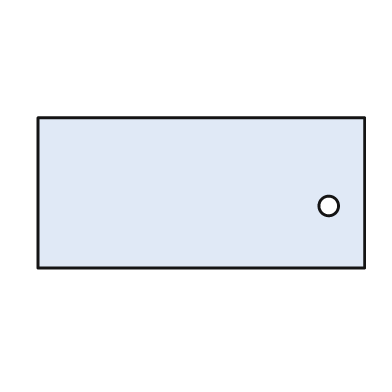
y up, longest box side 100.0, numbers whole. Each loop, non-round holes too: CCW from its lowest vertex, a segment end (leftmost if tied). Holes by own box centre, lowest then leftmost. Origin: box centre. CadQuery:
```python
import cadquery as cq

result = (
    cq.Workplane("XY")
    .moveTo(-50.0, -23.0)
    .lineTo(50.0, -23.0)
    .lineTo(50.0, 23.0)
    .lineTo(-50.0, 23.0)
    .close()
    .moveTo(39.0, -4.0)
    .circle(3.0)
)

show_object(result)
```